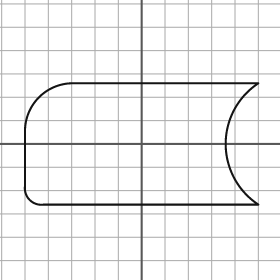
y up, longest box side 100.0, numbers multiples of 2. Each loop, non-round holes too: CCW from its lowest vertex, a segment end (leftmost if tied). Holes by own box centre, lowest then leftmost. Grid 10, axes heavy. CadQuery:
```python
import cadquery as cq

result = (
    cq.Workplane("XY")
    .moveTo(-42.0, -26.0)
    .lineTo(50.0, -26.0)
    .threePointArc((36.0, 0.0), (50.0, 26.0))
    .lineTo(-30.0, 26.0)
    .threePointArc((-44.0, 20.0), (-50.0, 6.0))
    .lineTo(-50.0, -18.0)
    .threePointArc((-48.0, -24.0), (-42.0, -26.0))
    .close()
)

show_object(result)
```